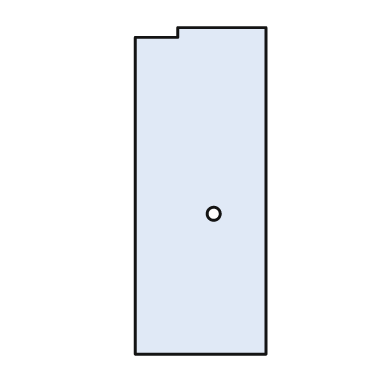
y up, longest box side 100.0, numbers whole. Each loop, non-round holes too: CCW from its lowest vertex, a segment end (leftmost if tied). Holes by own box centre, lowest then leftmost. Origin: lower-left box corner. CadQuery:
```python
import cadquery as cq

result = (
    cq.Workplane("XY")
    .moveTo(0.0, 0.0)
    .lineTo(40.0, 0.0)
    .lineTo(40.0, 100.0)
    .lineTo(13.0, 100.0)
    .lineTo(13.0, 97.0)
    .lineTo(0.0, 97.0)
    .close()
    .moveTo(24.0, 43.0)
    .circle(2.0)
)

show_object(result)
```